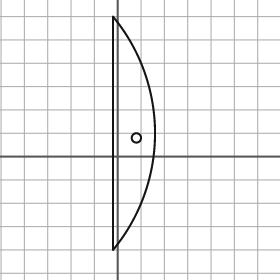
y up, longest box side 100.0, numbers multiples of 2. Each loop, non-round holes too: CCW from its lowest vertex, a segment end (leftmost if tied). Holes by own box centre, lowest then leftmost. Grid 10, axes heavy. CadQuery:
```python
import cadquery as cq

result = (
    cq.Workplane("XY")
    .moveTo(-2.0, -40.0)
    .threePointArc((16.0, 10.0), (-2.0, 60.0))
    .close()
    .moveTo(8.0, 8.0)
    .circle(2.0)
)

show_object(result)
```